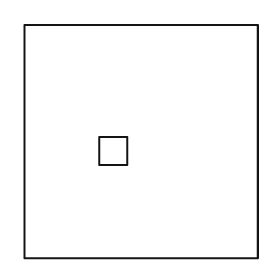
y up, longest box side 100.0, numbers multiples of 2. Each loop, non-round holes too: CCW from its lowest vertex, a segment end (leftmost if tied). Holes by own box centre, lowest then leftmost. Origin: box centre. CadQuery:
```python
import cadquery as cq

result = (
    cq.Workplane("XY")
    .moveTo(-50.0, -50.0)
    .lineTo(50.0, -50.0)
    .lineTo(50.0, 50.0)
    .lineTo(-50.0, 50.0)
    .close()
    .moveTo(-18.0, -10.0)
    .lineTo(-6.0, -10.0)
    .lineTo(-6.0, 2.0)
    .lineTo(-18.0, 2.0)
    .close()
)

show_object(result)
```